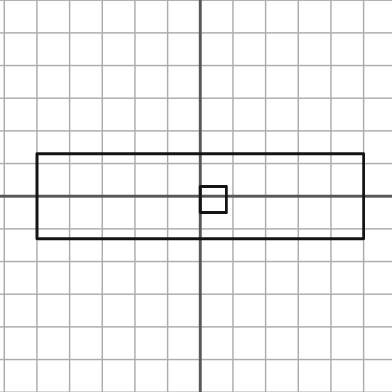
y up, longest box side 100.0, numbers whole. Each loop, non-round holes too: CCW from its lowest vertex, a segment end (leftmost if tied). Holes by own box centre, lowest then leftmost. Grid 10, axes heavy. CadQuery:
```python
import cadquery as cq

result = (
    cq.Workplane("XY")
    .moveTo(-50.0, -13.0)
    .lineTo(50.0, -13.0)
    .lineTo(50.0, 13.0)
    .lineTo(-50.0, 13.0)
    .close()
    .moveTo(0.0, -5.0)
    .lineTo(8.0, -5.0)
    .lineTo(8.0, 3.0)
    .lineTo(0.0, 3.0)
    .close()
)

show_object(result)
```